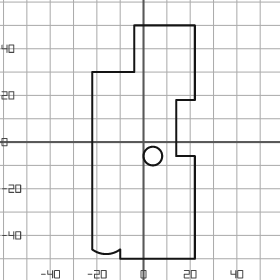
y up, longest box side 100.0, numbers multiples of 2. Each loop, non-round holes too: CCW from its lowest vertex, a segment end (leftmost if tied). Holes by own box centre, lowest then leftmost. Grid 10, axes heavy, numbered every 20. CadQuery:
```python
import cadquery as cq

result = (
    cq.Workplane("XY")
    .moveTo(-10.0, -50.0)
    .lineTo(22.0, -50.0)
    .lineTo(22.0, -6.0)
    .lineTo(14.0, -6.0)
    .lineTo(14.0, 18.0)
    .lineTo(22.0, 18.0)
    .lineTo(22.0, 50.0)
    .lineTo(-4.0, 50.0)
    .lineTo(-4.0, 30.0)
    .lineTo(-22.0, 30.0)
    .lineTo(-22.0, -46.0)
    .threePointArc((-16.0, -48.0), (-10.0, -46.0))
    .close()
    .moveTo(4.0, -6.0)
    .circle(4.0)
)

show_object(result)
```